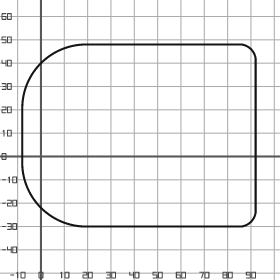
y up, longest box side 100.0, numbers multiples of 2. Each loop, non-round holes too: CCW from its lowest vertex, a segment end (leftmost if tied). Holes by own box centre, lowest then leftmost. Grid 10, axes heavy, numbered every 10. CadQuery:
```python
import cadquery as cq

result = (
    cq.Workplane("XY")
    .moveTo(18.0, -30.0)
    .lineTo(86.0, -30.0)
    .threePointArc((90.0, -28.0), (92.0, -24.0))
    .lineTo(92.0, 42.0)
    .threePointArc((90.0, 46.0), (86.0, 48.0))
    .lineTo(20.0, 48.0)
    .threePointArc((0.0, 40.0), (-8.0, 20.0))
    .lineTo(-8.0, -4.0)
    .threePointArc((0.0, -22.0), (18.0, -30.0))
    .close()
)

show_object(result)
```